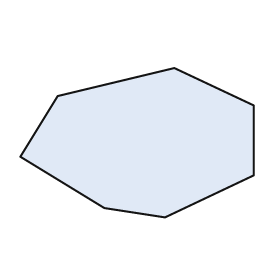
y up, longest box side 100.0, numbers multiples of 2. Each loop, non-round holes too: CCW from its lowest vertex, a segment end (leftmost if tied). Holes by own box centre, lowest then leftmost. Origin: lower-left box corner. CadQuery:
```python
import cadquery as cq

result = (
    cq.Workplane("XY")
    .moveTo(62.0, 0.0)
    .lineTo(100.0, 18.0)
    .lineTo(100.0, 48.0)
    .lineTo(66.0, 64.0)
    .lineTo(16.0, 52.0)
    .lineTo(0.0, 26.0)
    .lineTo(36.0, 4.0)
    .close()
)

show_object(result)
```